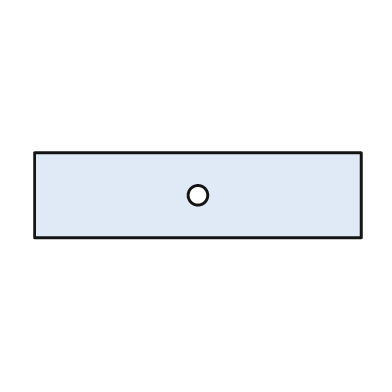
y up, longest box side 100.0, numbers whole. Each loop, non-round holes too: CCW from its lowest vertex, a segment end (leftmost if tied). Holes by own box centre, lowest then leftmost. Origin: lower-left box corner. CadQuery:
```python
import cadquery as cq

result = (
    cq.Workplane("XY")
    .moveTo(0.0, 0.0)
    .lineTo(100.0, 0.0)
    .lineTo(100.0, 26.0)
    .lineTo(0.0, 26.0)
    .close()
    .moveTo(50.0, 13.0)
    .circle(3.0)
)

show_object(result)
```